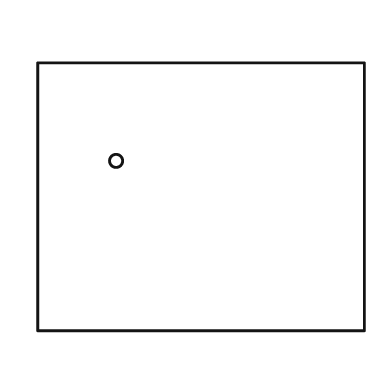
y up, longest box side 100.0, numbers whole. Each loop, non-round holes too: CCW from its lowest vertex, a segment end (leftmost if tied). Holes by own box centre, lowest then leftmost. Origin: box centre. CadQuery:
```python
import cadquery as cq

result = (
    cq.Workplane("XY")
    .moveTo(-50.0, -41.0)
    .lineTo(50.0, -41.0)
    .lineTo(50.0, 41.0)
    .lineTo(-50.0, 41.0)
    .close()
    .moveTo(-26.0, 11.0)
    .circle(2.0)
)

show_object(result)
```